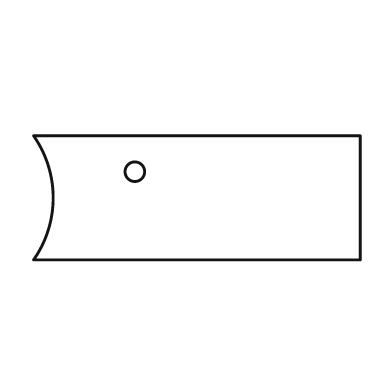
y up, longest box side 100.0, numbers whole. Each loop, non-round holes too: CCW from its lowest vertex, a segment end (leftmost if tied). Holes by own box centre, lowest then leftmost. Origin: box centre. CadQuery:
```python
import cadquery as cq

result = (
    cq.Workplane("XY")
    .moveTo(-50.0, -19.0)
    .lineTo(50.0, -19.0)
    .lineTo(50.0, 19.0)
    .lineTo(-50.0, 19.0)
    .threePointArc((-44.0, 0.0), (-50.0, -19.0))
    .close()
    .moveTo(-19.0, 8.0)
    .circle(3.0)
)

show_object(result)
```